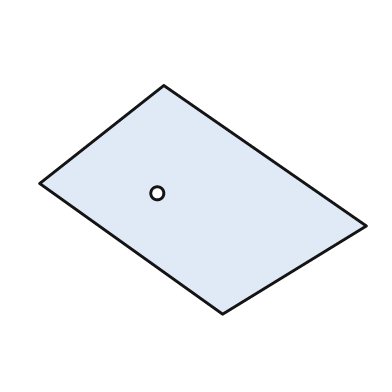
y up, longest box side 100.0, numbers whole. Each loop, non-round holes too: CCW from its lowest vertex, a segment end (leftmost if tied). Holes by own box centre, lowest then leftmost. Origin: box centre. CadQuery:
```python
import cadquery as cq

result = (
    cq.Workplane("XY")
    .moveTo(6.0, -35.0)
    .lineTo(50.0, -8.0)
    .lineTo(-12.0, 35.0)
    .lineTo(-50.0, 5.0)
    .close()
    .moveTo(-14.0, 2.0)
    .circle(2.0)
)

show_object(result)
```